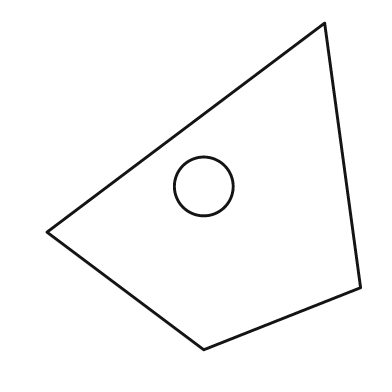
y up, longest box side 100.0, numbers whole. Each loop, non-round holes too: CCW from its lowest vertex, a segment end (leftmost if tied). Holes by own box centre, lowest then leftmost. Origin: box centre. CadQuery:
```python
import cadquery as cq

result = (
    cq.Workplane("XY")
    .moveTo(0.0, -50.0)
    .lineTo(48.0, -31.0)
    .lineTo(37.0, 50.0)
    .lineTo(-48.0, -14.0)
    .close()
    .moveTo(0.0, 0.0)
    .circle(9.0)
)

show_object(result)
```